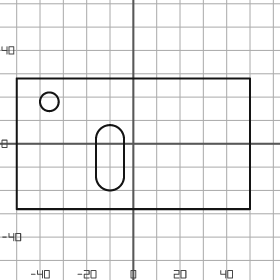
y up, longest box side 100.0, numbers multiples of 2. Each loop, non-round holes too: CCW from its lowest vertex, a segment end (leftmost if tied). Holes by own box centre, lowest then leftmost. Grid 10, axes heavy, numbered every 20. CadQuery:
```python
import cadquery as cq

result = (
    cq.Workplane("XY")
    .moveTo(-50.0, -28.0)
    .lineTo(50.0, -28.0)
    .lineTo(50.0, 28.0)
    .lineTo(-50.0, 28.0)
    .close()
    .moveTo(-16.0, -14.0)
    .threePointArc((-10.0, -20.0), (-4.0, -14.0))
    .lineTo(-4.0, 2.0)
    .threePointArc((-10.0, 8.0), (-16.0, 2.0))
    .close()
    .moveTo(-36.0, 18.0)
    .circle(4.0)
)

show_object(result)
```